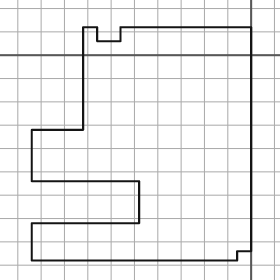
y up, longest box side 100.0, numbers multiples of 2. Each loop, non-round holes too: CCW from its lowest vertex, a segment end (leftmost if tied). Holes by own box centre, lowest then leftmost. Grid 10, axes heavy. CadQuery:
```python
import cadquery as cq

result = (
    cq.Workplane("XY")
    .moveTo(-94.0, -88.0)
    .lineTo(-6.0, -88.0)
    .lineTo(-6.0, -84.0)
    .lineTo(0.0, -84.0)
    .lineTo(0.0, 12.0)
    .lineTo(-56.0, 12.0)
    .lineTo(-56.0, 6.0)
    .lineTo(-66.0, 6.0)
    .lineTo(-66.0, 12.0)
    .lineTo(-72.0, 12.0)
    .lineTo(-72.0, -32.0)
    .lineTo(-94.0, -32.0)
    .lineTo(-94.0, -54.0)
    .lineTo(-48.0, -54.0)
    .lineTo(-48.0, -72.0)
    .lineTo(-94.0, -72.0)
    .close()
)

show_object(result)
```